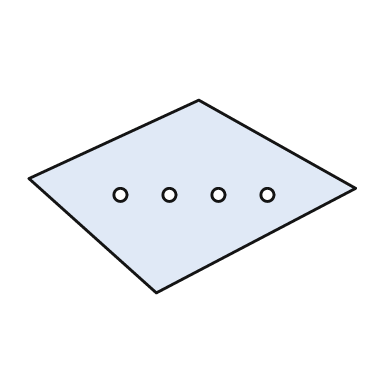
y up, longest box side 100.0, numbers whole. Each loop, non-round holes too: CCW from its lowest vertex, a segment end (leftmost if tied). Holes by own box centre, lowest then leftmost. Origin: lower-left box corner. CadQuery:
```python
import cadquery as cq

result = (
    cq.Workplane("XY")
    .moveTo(39.0, 0.0)
    .lineTo(100.0, 32.0)
    .lineTo(52.0, 59.0)
    .lineTo(0.0, 35.0)
    .close()
    .moveTo(28.0, 30.0)
    .circle(2.0)
    .moveTo(43.0, 30.0)
    .circle(2.0)
    .moveTo(58.0, 30.0)
    .circle(2.0)
    .moveTo(73.0, 30.0)
    .circle(2.0)
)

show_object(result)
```